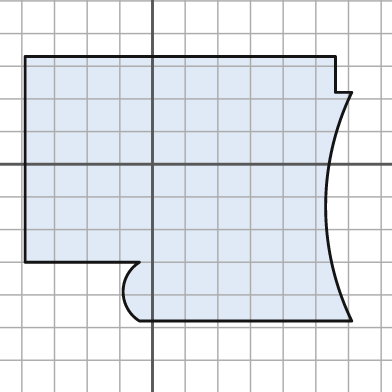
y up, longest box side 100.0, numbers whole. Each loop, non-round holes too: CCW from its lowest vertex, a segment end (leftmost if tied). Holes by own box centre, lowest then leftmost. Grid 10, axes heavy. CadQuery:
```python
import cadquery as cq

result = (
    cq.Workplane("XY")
    .moveTo(-4.0, -48.0)
    .lineTo(61.0, -48.0)
    .threePointArc((53.0, -13.0), (61.0, 22.0))
    .lineTo(56.0, 22.0)
    .lineTo(56.0, 33.0)
    .lineTo(-39.0, 33.0)
    .lineTo(-39.0, -30.0)
    .lineTo(-4.0, -30.0)
    .threePointArc((-9.0, -39.0), (-4.0, -48.0))
    .close()
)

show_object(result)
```